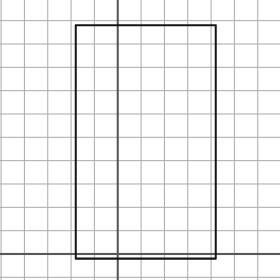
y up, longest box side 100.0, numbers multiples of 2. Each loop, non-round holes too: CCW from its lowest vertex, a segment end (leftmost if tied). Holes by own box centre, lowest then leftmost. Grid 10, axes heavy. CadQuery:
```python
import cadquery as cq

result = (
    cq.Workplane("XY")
    .moveTo(-18.0, -2.0)
    .lineTo(42.0, -2.0)
    .lineTo(42.0, 98.0)
    .lineTo(-18.0, 98.0)
    .close()
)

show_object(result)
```